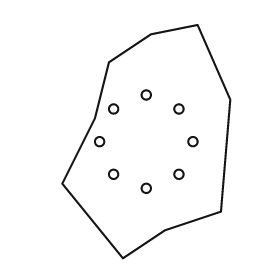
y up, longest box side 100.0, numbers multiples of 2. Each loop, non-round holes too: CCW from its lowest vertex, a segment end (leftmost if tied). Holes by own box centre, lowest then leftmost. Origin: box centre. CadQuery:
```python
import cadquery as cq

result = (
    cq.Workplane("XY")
    .moveTo(-10.0, -50.0)
    .lineTo(8.0, -38.0)
    .lineTo(32.0, -30.0)
    .lineTo(36.0, 18.0)
    .lineTo(22.0, 50.0)
    .lineTo(2.0, 46.0)
    .lineTo(-16.0, 34.0)
    .lineTo(-22.0, 10.0)
    .lineTo(-36.0, -18.0)
    .close()
    .moveTo(0.0, -20.0)
    .circle(2.0)
    .moveTo(-14.0, -14.0)
    .circle(2.0)
    .moveTo(14.0, -14.0)
    .circle(2.0)
    .moveTo(-20.0, 0.0)
    .circle(2.0)
    .moveTo(20.0, 0.0)
    .circle(2.0)
    .moveTo(-14.0, 14.0)
    .circle(2.0)
    .moveTo(14.0, 14.0)
    .circle(2.0)
    .moveTo(0.0, 20.0)
    .circle(2.0)
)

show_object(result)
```